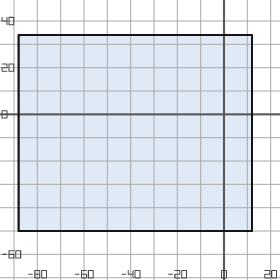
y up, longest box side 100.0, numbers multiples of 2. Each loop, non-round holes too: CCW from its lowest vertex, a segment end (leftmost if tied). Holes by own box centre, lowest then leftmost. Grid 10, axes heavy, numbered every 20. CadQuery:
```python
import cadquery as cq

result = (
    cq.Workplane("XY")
    .moveTo(-88.0, -50.0)
    .lineTo(12.0, -50.0)
    .lineTo(12.0, 34.0)
    .lineTo(-88.0, 34.0)
    .close()
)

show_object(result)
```